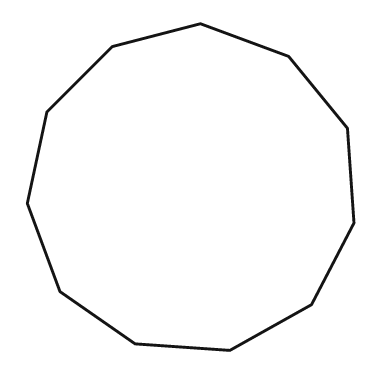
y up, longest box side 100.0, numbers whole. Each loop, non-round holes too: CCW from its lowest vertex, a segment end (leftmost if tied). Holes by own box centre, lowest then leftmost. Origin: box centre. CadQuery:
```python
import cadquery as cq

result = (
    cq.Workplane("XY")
    .moveTo(12.0, -50.0)
    .lineTo(37.0, -36.0)
    .lineTo(50.0, -11.0)
    .lineTo(48.0, 18.0)
    .lineTo(30.0, 40.0)
    .lineTo(3.0, 50.0)
    .lineTo(-24.0, 43.0)
    .lineTo(-44.0, 23.0)
    .lineTo(-50.0, -5.0)
    .lineTo(-40.0, -32.0)
    .lineTo(-17.0, -48.0)
    .close()
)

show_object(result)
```